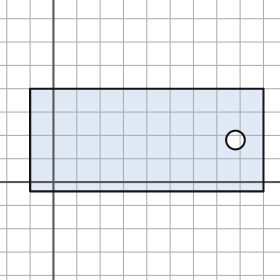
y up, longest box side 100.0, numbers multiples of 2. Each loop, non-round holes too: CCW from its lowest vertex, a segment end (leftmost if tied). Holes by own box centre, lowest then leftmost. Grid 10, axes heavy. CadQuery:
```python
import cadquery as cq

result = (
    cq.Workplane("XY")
    .moveTo(-10.0, -4.0)
    .lineTo(90.0, -4.0)
    .lineTo(90.0, 40.0)
    .lineTo(-10.0, 40.0)
    .close()
    .moveTo(78.0, 18.0)
    .circle(4.0)
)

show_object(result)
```